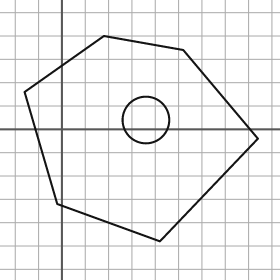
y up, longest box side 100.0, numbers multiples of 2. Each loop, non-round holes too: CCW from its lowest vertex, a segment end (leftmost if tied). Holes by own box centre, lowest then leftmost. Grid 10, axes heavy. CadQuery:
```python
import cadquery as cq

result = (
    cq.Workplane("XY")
    .moveTo(42.0, -48.0)
    .lineTo(84.0, -4.0)
    .lineTo(52.0, 34.0)
    .lineTo(18.0, 40.0)
    .lineTo(-16.0, 16.0)
    .lineTo(-2.0, -32.0)
    .close()
    .moveTo(36.0, 4.0)
    .circle(10.0)
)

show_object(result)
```